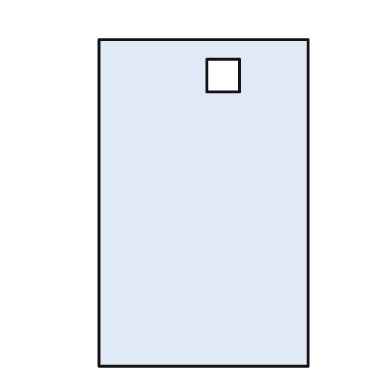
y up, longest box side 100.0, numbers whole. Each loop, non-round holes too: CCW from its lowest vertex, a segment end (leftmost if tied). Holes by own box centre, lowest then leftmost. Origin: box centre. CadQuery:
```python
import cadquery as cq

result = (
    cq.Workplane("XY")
    .moveTo(-32.0, -50.0)
    .lineTo(32.0, -50.0)
    .lineTo(32.0, 50.0)
    .lineTo(-32.0, 50.0)
    .close()
    .moveTo(1.0, 34.0)
    .lineTo(11.0, 34.0)
    .lineTo(11.0, 44.0)
    .lineTo(1.0, 44.0)
    .close()
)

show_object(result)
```